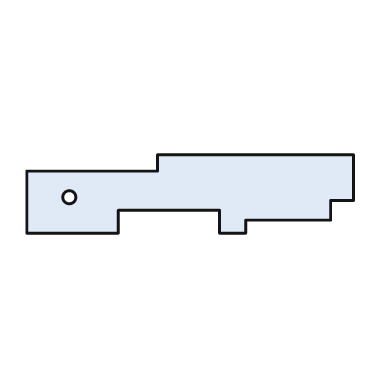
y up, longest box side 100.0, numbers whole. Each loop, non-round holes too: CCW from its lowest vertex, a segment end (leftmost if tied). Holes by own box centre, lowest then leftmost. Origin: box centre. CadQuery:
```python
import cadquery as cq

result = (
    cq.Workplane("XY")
    .moveTo(-50.0, -12.0)
    .lineTo(-22.0, -12.0)
    .lineTo(-22.0, -5.0)
    .lineTo(9.0, -5.0)
    .lineTo(9.0, -12.0)
    .lineTo(17.0, -12.0)
    .lineTo(17.0, -8.0)
    .lineTo(43.0, -8.0)
    .lineTo(43.0, -2.0)
    .lineTo(50.0, -2.0)
    .lineTo(50.0, 12.0)
    .lineTo(-10.0, 12.0)
    .lineTo(-10.0, 7.0)
    .lineTo(-50.0, 7.0)
    .close()
    .moveTo(-37.0, -1.0)
    .circle(2.0)
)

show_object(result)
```